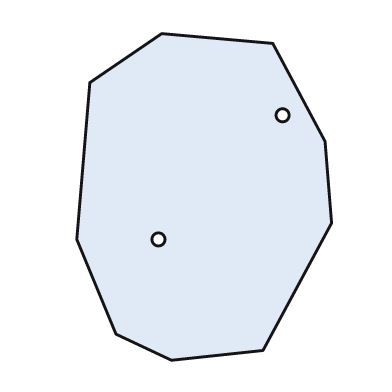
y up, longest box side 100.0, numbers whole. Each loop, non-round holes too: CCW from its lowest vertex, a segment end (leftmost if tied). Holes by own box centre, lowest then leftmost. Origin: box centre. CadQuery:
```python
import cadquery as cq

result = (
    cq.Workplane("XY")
    .moveTo(-10.0, -50.0)
    .lineTo(18.0, -47.0)
    .lineTo(39.0, -8.0)
    .lineTo(37.0, 17.0)
    .lineTo(21.0, 47.0)
    .lineTo(-13.0, 50.0)
    .lineTo(-35.0, 35.0)
    .lineTo(-39.0, -13.0)
    .lineTo(-27.0, -42.0)
    .close()
    .moveTo(-14.0, -13.0)
    .circle(2.0)
    .moveTo(24.0, 25.0)
    .circle(2.0)
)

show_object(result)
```